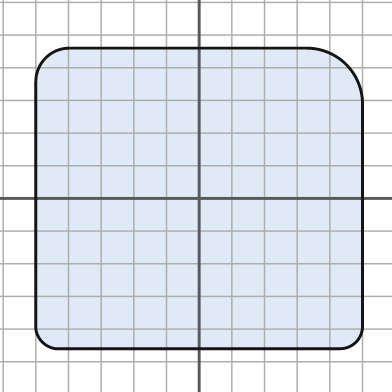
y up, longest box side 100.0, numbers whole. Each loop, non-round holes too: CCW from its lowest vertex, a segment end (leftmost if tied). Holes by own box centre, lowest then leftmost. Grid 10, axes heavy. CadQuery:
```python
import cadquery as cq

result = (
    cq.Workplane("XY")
    .moveTo(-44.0, -46.0)
    .lineTo(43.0, -46.0)
    .threePointArc((48.0, -44.0), (50.0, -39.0))
    .lineTo(50.0, 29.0)
    .threePointArc((45.0, 41.0), (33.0, 46.0))
    .lineTo(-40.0, 46.0)
    .threePointArc((-47.0, 43.0), (-50.0, 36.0))
    .lineTo(-50.0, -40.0)
    .threePointArc((-48.0, -44.0), (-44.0, -46.0))
    .close()
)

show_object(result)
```